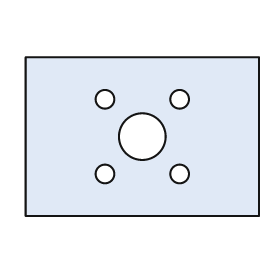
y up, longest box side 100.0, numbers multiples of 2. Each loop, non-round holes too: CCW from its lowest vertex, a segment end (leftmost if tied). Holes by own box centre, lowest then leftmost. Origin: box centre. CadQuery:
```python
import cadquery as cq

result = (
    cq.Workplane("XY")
    .moveTo(-50.0, -34.0)
    .lineTo(50.0, -34.0)
    .lineTo(50.0, 34.0)
    .lineTo(-50.0, 34.0)
    .close()
    .moveTo(-16.0, -16.0)
    .circle(4.0)
    .moveTo(16.0, -16.0)
    .circle(4.0)
    .moveTo(0.0, 0.0)
    .circle(10.0)
    .moveTo(-16.0, 16.0)
    .circle(4.0)
    .moveTo(16.0, 16.0)
    .circle(4.0)
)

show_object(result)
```